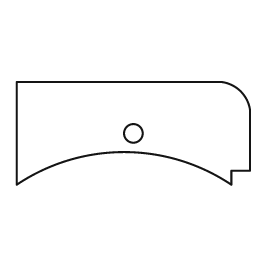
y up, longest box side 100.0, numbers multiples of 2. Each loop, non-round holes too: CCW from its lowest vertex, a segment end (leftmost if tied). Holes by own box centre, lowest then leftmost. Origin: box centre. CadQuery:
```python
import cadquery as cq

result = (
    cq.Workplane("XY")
    .moveTo(-50.0, -22.0)
    .threePointArc((-4.0, -8.0), (42.0, -22.0))
    .lineTo(42.0, -16.0)
    .lineTo(50.0, -16.0)
    .lineTo(50.0, 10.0)
    .threePointArc((46.0, 18.0), (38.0, 22.0))
    .lineTo(-50.0, 22.0)
    .close()
    .moveTo(0.0, 0.0)
    .circle(4.0)
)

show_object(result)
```